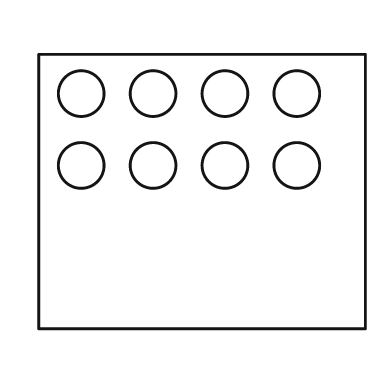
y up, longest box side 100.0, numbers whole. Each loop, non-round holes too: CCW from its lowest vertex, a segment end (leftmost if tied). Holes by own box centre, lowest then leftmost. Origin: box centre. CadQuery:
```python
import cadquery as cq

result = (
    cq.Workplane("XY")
    .moveTo(-50.0, -42.0)
    .lineTo(50.0, -42.0)
    .lineTo(50.0, 42.0)
    .lineTo(-50.0, 42.0)
    .close()
    .moveTo(-37.0, 8.0)
    .circle(7.0)
    .moveTo(-15.0, 8.0)
    .circle(7.0)
    .moveTo(7.0, 8.0)
    .circle(7.0)
    .moveTo(29.0, 8.0)
    .circle(7.0)
    .moveTo(-37.0, 30.0)
    .circle(7.0)
    .moveTo(-15.0, 30.0)
    .circle(7.0)
    .moveTo(7.0, 30.0)
    .circle(7.0)
    .moveTo(29.0, 30.0)
    .circle(7.0)
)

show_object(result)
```